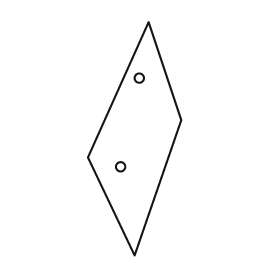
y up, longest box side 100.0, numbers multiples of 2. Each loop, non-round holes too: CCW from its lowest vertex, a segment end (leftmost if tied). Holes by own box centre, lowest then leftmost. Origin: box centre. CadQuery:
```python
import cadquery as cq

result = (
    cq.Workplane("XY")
    .moveTo(0.0, -50.0)
    .lineTo(20.0, 8.0)
    .lineTo(6.0, 50.0)
    .lineTo(-20.0, -8.0)
    .close()
    .moveTo(-6.0, -12.0)
    .circle(2.0)
    .moveTo(2.0, 26.0)
    .circle(2.0)
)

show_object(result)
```